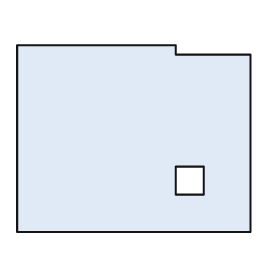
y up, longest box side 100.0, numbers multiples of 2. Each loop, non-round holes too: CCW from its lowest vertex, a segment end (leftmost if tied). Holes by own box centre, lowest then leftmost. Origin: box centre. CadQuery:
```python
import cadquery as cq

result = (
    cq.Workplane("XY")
    .moveTo(-50.0, -40.0)
    .lineTo(50.0, -40.0)
    .lineTo(50.0, 36.0)
    .lineTo(18.0, 36.0)
    .lineTo(18.0, 40.0)
    .lineTo(-50.0, 40.0)
    .close()
    .moveTo(18.0, -24.0)
    .lineTo(30.0, -24.0)
    .lineTo(30.0, -12.0)
    .lineTo(18.0, -12.0)
    .close()
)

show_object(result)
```